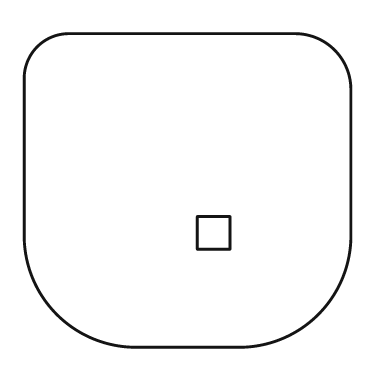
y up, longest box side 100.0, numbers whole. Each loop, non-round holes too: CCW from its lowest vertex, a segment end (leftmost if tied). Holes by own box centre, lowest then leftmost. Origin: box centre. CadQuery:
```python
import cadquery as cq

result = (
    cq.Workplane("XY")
    .moveTo(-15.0, -48.0)
    .lineTo(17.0, -48.0)
    .threePointArc((40.0, -38.0), (50.0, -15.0))
    .lineTo(50.0, 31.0)
    .threePointArc((45.0, 43.0), (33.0, 48.0))
    .lineTo(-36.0, 48.0)
    .threePointArc((-46.0, 44.0), (-50.0, 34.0))
    .lineTo(-50.0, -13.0)
    .threePointArc((-40.0, -38.0), (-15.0, -48.0))
    .close()
    .moveTo(3.0, -18.0)
    .lineTo(13.0, -18.0)
    .lineTo(13.0, -8.0)
    .lineTo(3.0, -8.0)
    .close()
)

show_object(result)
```